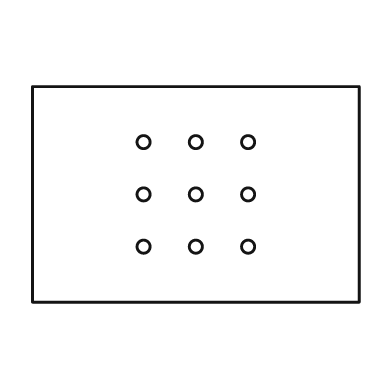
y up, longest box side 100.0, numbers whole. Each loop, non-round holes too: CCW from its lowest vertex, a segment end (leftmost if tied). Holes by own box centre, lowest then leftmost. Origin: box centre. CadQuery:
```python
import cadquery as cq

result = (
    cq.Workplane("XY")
    .moveTo(-50.0, -33.0)
    .lineTo(50.0, -33.0)
    .lineTo(50.0, 33.0)
    .lineTo(-50.0, 33.0)
    .close()
    .moveTo(-16.0, -16.0)
    .circle(2.0)
    .moveTo(0.0, -16.0)
    .circle(2.0)
    .moveTo(16.0, -16.0)
    .circle(2.0)
    .moveTo(-16.0, 0.0)
    .circle(2.0)
    .moveTo(0.0, 0.0)
    .circle(2.0)
    .moveTo(16.0, 0.0)
    .circle(2.0)
    .moveTo(-16.0, 16.0)
    .circle(2.0)
    .moveTo(0.0, 16.0)
    .circle(2.0)
    .moveTo(16.0, 16.0)
    .circle(2.0)
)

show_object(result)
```